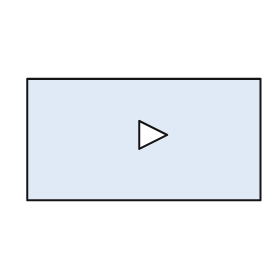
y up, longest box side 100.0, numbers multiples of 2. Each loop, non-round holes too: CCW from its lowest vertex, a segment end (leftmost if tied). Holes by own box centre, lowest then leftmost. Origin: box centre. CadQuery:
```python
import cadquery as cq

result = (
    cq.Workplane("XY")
    .moveTo(-50.0, -26.0)
    .lineTo(50.0, -26.0)
    .lineTo(50.0, 26.0)
    .lineTo(-50.0, 26.0)
    .close()
    .moveTo(-2.0, -4.0)
    .lineTo(10.0, 2.0)
    .lineTo(-2.0, 8.0)
    .close()
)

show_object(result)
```